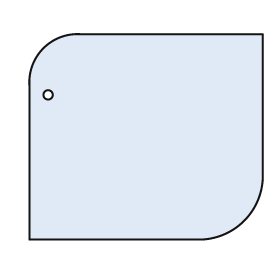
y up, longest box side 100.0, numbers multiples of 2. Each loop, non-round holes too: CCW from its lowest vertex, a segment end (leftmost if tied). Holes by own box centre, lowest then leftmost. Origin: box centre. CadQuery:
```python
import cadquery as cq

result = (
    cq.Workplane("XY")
    .moveTo(-50.0, -44.0)
    .lineTo(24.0, -44.0)
    .threePointArc((42.0, -36.0), (50.0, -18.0))
    .lineTo(50.0, 44.0)
    .lineTo(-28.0, 44.0)
    .threePointArc((-44.0, 38.0), (-50.0, 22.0))
    .close()
    .moveTo(-42.0, 18.0)
    .circle(2.0)
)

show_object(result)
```